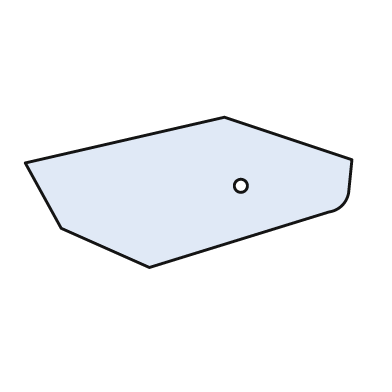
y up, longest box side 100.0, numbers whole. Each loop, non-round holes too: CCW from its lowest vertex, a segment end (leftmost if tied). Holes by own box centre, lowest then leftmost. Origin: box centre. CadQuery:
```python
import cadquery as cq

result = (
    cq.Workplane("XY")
    .moveTo(-12.0, -23.0)
    .lineTo(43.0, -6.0)
    .threePointArc((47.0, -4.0), (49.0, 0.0))
    .lineTo(50.0, 10.0)
    .lineTo(11.0, 23.0)
    .lineTo(-50.0, 9.0)
    .lineTo(-39.0, -11.0)
    .close()
    .moveTo(16.0, 2.0)
    .circle(2.0)
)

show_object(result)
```